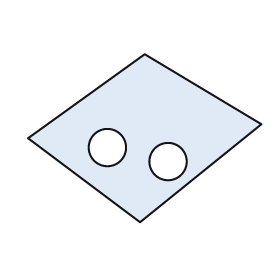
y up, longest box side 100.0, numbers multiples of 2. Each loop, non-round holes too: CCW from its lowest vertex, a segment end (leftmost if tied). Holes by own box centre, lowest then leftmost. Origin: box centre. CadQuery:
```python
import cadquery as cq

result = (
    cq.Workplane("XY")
    .moveTo(-2.0, -36.0)
    .lineTo(50.0, 6.0)
    .lineTo(0.0, 36.0)
    .lineTo(-50.0, 0.0)
    .close()
    .moveTo(10.0, -10.0)
    .circle(8.0)
    .moveTo(-16.0, -4.0)
    .circle(8.0)
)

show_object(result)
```